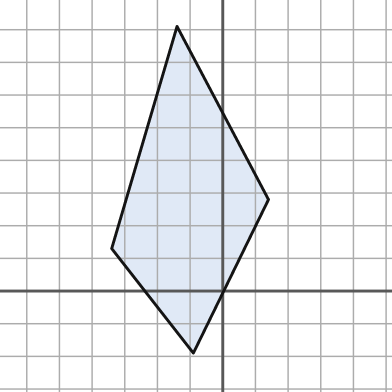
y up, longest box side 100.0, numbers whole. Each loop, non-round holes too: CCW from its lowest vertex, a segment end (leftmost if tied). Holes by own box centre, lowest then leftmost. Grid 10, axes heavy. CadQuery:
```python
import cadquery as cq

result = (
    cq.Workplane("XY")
    .moveTo(-9.0, -19.0)
    .lineTo(14.0, 28.0)
    .lineTo(-14.0, 81.0)
    .lineTo(-34.0, 13.0)
    .close()
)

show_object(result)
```